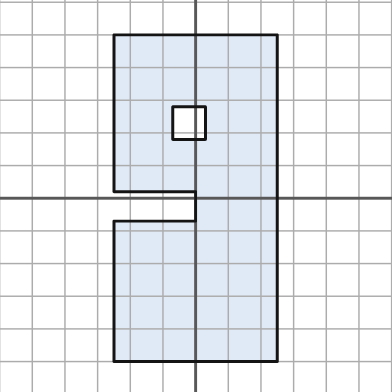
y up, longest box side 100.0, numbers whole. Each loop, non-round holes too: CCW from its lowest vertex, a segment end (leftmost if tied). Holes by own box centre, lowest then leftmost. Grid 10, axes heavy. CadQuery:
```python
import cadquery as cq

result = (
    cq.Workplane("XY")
    .moveTo(-25.0, -50.0)
    .lineTo(25.0, -50.0)
    .lineTo(25.0, 50.0)
    .lineTo(-25.0, 50.0)
    .lineTo(-25.0, 2.0)
    .lineTo(0.0, 2.0)
    .lineTo(0.0, -7.0)
    .lineTo(-25.0, -7.0)
    .close()
    .moveTo(-7.0, 18.0)
    .lineTo(3.0, 18.0)
    .lineTo(3.0, 28.0)
    .lineTo(-7.0, 28.0)
    .close()
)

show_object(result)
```